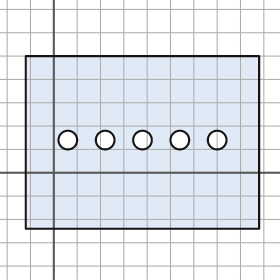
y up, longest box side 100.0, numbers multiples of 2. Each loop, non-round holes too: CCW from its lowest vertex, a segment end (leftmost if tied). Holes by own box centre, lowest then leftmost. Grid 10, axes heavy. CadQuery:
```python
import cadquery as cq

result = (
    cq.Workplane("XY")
    .moveTo(-12.0, -24.0)
    .lineTo(88.0, -24.0)
    .lineTo(88.0, 50.0)
    .lineTo(-12.0, 50.0)
    .close()
    .moveTo(6.0, 14.0)
    .circle(4.0)
    .moveTo(22.0, 14.0)
    .circle(4.0)
    .moveTo(38.0, 14.0)
    .circle(4.0)
    .moveTo(54.0, 14.0)
    .circle(4.0)
    .moveTo(70.0, 14.0)
    .circle(4.0)
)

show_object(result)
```